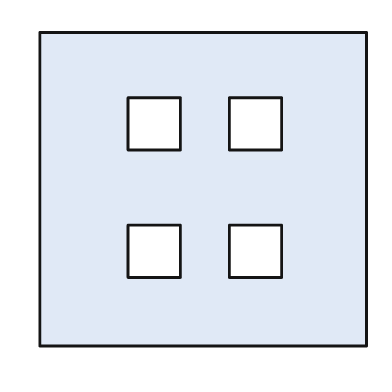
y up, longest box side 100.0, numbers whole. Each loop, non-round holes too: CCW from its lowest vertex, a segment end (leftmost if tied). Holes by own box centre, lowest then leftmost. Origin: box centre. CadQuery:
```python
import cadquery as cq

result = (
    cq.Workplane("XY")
    .moveTo(-50.0, -48.0)
    .lineTo(50.0, -48.0)
    .lineTo(50.0, 48.0)
    .lineTo(-50.0, 48.0)
    .close()
    .moveTo(-23.0, -27.0)
    .lineTo(-7.0, -27.0)
    .lineTo(-7.0, -11.0)
    .lineTo(-23.0, -11.0)
    .close()
    .moveTo(8.0, -27.0)
    .lineTo(24.0, -27.0)
    .lineTo(24.0, -11.0)
    .lineTo(8.0, -11.0)
    .close()
    .moveTo(-23.0, 12.0)
    .lineTo(-7.0, 12.0)
    .lineTo(-7.0, 28.0)
    .lineTo(-23.0, 28.0)
    .close()
    .moveTo(8.0, 12.0)
    .lineTo(24.0, 12.0)
    .lineTo(24.0, 28.0)
    .lineTo(8.0, 28.0)
    .close()
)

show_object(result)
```